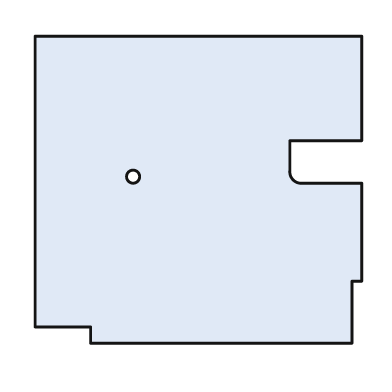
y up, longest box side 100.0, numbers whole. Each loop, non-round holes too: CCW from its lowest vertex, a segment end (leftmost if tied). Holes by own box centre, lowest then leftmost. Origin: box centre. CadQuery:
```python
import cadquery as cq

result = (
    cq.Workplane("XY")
    .moveTo(-33.0, -47.0)
    .lineTo(47.0, -47.0)
    .lineTo(47.0, -28.0)
    .lineTo(50.0, -28.0)
    .lineTo(50.0, 2.0)
    .lineTo(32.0, 2.0)
    .threePointArc((29.0, 3.0), (28.0, 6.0))
    .lineTo(28.0, 15.0)
    .lineTo(50.0, 15.0)
    .lineTo(50.0, 47.0)
    .lineTo(-50.0, 47.0)
    .lineTo(-50.0, -42.0)
    .lineTo(-33.0, -42.0)
    .close()
    .moveTo(-20.0, 4.0)
    .circle(2.0)
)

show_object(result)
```